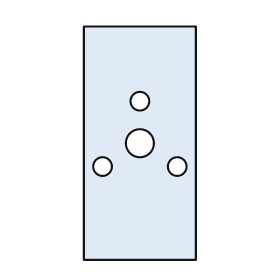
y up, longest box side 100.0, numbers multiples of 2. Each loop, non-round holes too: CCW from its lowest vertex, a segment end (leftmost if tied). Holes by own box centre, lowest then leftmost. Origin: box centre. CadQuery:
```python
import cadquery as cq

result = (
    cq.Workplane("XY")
    .moveTo(-24.0, -50.0)
    .lineTo(24.0, -50.0)
    .lineTo(24.0, 50.0)
    .lineTo(-24.0, 50.0)
    .close()
    .moveTo(-16.0, -10.0)
    .circle(4.0)
    .moveTo(16.0, -10.0)
    .circle(4.0)
    .moveTo(0.0, 0.0)
    .circle(6.0)
    .moveTo(0.0, 18.0)
    .circle(4.0)
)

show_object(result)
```